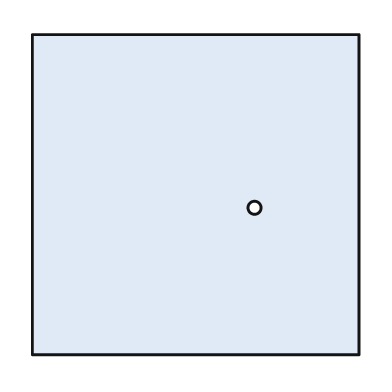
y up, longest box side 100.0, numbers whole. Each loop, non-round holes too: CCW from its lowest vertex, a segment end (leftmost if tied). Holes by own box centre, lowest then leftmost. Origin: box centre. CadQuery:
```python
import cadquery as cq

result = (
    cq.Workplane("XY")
    .moveTo(-50.0, -49.0)
    .lineTo(50.0, -49.0)
    .lineTo(50.0, 49.0)
    .lineTo(-50.0, 49.0)
    .close()
    .moveTo(18.0, -4.0)
    .circle(2.0)
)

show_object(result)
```